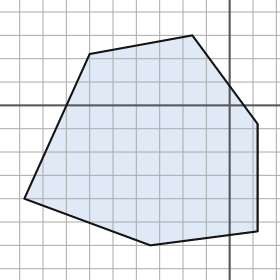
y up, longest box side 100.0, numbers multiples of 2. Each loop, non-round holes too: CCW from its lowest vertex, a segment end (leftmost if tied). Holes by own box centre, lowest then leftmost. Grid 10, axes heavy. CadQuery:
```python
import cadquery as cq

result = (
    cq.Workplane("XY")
    .moveTo(-34.0, -60.0)
    .lineTo(12.0, -54.0)
    .lineTo(12.0, -8.0)
    .lineTo(-16.0, 30.0)
    .lineTo(-60.0, 22.0)
    .lineTo(-88.0, -40.0)
    .close()
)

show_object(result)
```